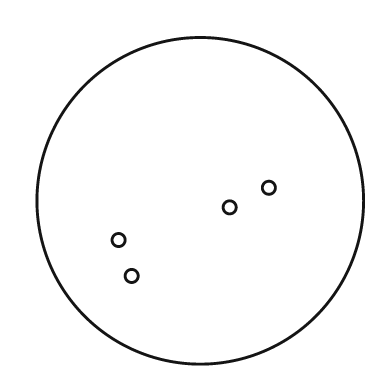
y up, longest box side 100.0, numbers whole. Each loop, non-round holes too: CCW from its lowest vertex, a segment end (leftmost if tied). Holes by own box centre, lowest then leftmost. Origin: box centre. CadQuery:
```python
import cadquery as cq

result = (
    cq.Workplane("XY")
    .moveTo(0.0, 0.0)
    .circle(50.0)
    .moveTo(-21.0, -23.0)
    .circle(2.0)
    .moveTo(-25.0, -12.0)
    .circle(2.0)
    .moveTo(9.0, -2.0)
    .circle(2.0)
    .moveTo(21.0, 4.0)
    .circle(2.0)
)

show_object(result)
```